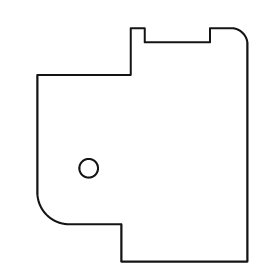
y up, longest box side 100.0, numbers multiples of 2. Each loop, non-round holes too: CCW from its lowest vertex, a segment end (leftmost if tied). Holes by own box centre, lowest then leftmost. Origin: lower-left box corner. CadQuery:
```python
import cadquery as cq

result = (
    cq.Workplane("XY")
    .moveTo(36.0, 0.0)
    .lineTo(90.0, 0.0)
    .lineTo(90.0, 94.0)
    .threePointArc((88.0, 98.0), (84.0, 100.0))
    .lineTo(74.0, 100.0)
    .lineTo(74.0, 94.0)
    .lineTo(46.0, 94.0)
    .lineTo(46.0, 100.0)
    .lineTo(40.0, 100.0)
    .lineTo(40.0, 80.0)
    .lineTo(0.0, 80.0)
    .lineTo(0.0, 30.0)
    .threePointArc((4.0, 20.0), (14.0, 16.0))
    .lineTo(36.0, 16.0)
    .close()
    .moveTo(22.0, 40.0)
    .circle(4.0)
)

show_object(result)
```